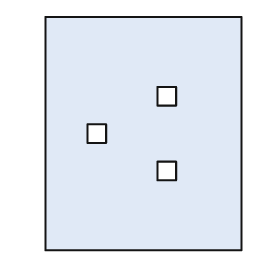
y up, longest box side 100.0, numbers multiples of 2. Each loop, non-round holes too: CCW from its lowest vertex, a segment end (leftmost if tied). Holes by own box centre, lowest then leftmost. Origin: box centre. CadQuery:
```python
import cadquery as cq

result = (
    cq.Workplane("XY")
    .moveTo(-42.0, -50.0)
    .lineTo(42.0, -50.0)
    .lineTo(42.0, 50.0)
    .lineTo(-42.0, 50.0)
    .close()
    .moveTo(6.0, -20.0)
    .lineTo(14.0, -20.0)
    .lineTo(14.0, -12.0)
    .lineTo(6.0, -12.0)
    .close()
    .moveTo(-24.0, -4.0)
    .lineTo(-16.0, -4.0)
    .lineTo(-16.0, 4.0)
    .lineTo(-24.0, 4.0)
    .close()
    .moveTo(6.0, 12.0)
    .lineTo(14.0, 12.0)
    .lineTo(14.0, 20.0)
    .lineTo(6.0, 20.0)
    .close()
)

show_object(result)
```